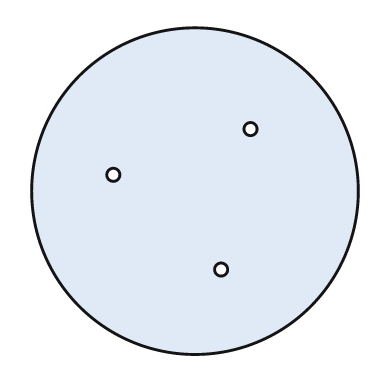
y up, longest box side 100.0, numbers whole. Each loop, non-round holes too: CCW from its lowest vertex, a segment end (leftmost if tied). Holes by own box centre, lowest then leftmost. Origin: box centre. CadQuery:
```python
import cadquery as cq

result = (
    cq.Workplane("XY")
    .moveTo(0.0, 0.0)
    .circle(50.0)
    .moveTo(8.0, -24.0)
    .circle(2.0)
    .moveTo(-25.0, 5.0)
    .circle(2.0)
    .moveTo(17.0, 19.0)
    .circle(2.0)
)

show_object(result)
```